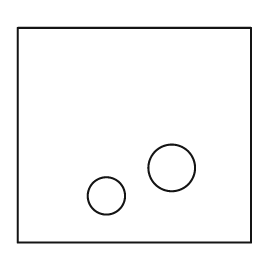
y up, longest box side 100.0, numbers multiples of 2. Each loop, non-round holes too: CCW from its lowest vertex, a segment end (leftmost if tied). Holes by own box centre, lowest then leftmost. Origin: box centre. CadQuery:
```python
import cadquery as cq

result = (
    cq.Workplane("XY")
    .moveTo(-50.0, -46.0)
    .lineTo(50.0, -46.0)
    .lineTo(50.0, 46.0)
    .lineTo(-50.0, 46.0)
    .close()
    .moveTo(-12.0, -26.0)
    .circle(8.0)
    .moveTo(16.0, -14.0)
    .circle(10.0)
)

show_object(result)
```